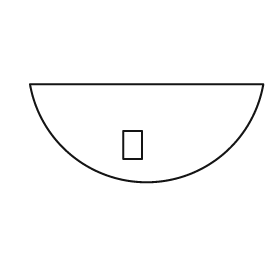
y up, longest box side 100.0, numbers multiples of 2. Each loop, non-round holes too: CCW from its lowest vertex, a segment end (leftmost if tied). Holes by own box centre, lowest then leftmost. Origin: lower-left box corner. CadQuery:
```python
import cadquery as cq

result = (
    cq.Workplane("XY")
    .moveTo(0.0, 42.0)
    .threePointArc((50.0, 0.0), (100.0, 42.0))
    .close()
    .moveTo(40.0, 10.0)
    .lineTo(48.0, 10.0)
    .lineTo(48.0, 22.0)
    .lineTo(40.0, 22.0)
    .close()
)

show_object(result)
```